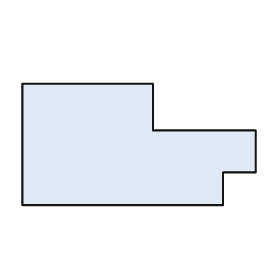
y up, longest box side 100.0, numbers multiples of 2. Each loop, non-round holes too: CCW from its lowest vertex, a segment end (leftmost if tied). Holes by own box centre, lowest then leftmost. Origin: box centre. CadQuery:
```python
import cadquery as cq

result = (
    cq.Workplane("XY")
    .moveTo(-50.0, -26.0)
    .lineTo(36.0, -26.0)
    .lineTo(36.0, -12.0)
    .lineTo(50.0, -12.0)
    .lineTo(50.0, 6.0)
    .lineTo(6.0, 6.0)
    .lineTo(6.0, 26.0)
    .lineTo(-50.0, 26.0)
    .close()
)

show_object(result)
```